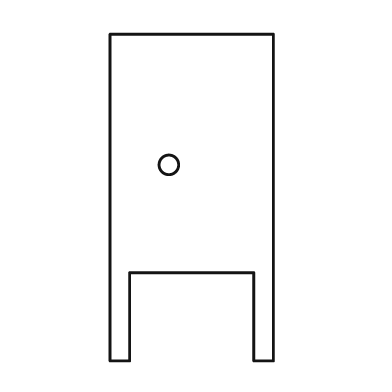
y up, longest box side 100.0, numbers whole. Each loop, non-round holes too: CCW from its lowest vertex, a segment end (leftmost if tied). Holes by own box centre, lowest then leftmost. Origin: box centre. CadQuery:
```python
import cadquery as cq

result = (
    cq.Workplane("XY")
    .moveTo(-25.0, -50.0)
    .lineTo(-19.0, -50.0)
    .lineTo(-19.0, -23.0)
    .lineTo(19.0, -23.0)
    .lineTo(19.0, -50.0)
    .lineTo(25.0, -50.0)
    .lineTo(25.0, 50.0)
    .lineTo(-25.0, 50.0)
    .close()
    .moveTo(-7.0, 10.0)
    .circle(3.0)
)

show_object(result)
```